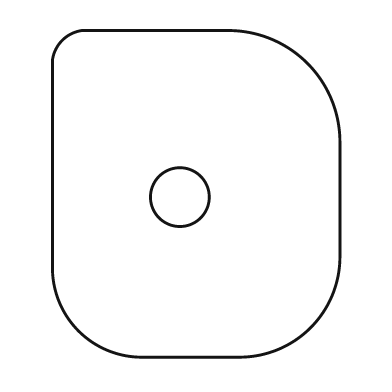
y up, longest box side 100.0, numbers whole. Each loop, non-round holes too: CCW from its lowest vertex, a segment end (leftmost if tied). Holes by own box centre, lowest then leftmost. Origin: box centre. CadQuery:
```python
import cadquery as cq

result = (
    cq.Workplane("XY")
    .moveTo(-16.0, -50.0)
    .lineTo(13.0, -50.0)
    .threePointArc((35.0, -41.0), (44.0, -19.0))
    .lineTo(44.0, 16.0)
    .threePointArc((34.0, 40.0), (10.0, 50.0))
    .lineTo(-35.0, 50.0)
    .threePointArc((-41.0, 47.0), (-44.0, 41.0))
    .lineTo(-44.0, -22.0)
    .threePointArc((-36.0, -42.0), (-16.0, -50.0))
    .close()
    .moveTo(-5.0, -1.0)
    .circle(9.0)
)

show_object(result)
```